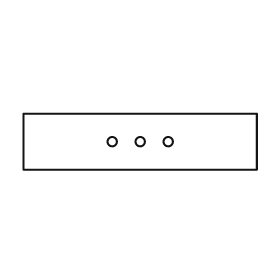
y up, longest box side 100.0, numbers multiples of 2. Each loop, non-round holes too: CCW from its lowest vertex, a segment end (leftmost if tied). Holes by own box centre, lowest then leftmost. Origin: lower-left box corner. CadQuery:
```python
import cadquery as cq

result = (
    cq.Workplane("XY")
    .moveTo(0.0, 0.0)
    .lineTo(100.0, 0.0)
    .lineTo(100.0, 24.0)
    .lineTo(0.0, 24.0)
    .close()
    .moveTo(38.0, 12.0)
    .circle(2.0)
    .moveTo(50.0, 12.0)
    .circle(2.0)
    .moveTo(62.0, 12.0)
    .circle(2.0)
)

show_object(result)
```